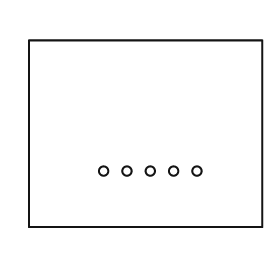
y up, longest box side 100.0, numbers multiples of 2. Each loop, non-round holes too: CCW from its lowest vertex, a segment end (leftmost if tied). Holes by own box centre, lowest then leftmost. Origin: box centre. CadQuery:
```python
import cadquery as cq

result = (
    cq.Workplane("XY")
    .moveTo(-50.0, -40.0)
    .lineTo(50.0, -40.0)
    .lineTo(50.0, 40.0)
    .lineTo(-50.0, 40.0)
    .close()
    .moveTo(-18.0, -16.0)
    .circle(2.0)
    .moveTo(-8.0, -16.0)
    .circle(2.0)
    .moveTo(2.0, -16.0)
    .circle(2.0)
    .moveTo(12.0, -16.0)
    .circle(2.0)
    .moveTo(22.0, -16.0)
    .circle(2.0)
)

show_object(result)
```